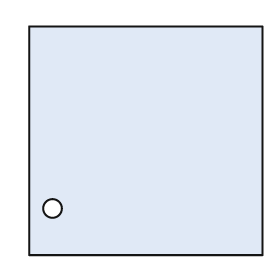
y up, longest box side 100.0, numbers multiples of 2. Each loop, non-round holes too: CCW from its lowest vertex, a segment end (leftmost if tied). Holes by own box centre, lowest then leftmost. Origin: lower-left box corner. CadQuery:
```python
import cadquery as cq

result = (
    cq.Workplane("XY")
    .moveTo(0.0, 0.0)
    .lineTo(100.0, 0.0)
    .lineTo(100.0, 98.0)
    .lineTo(0.0, 98.0)
    .close()
    .moveTo(10.0, 20.0)
    .circle(4.0)
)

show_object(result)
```